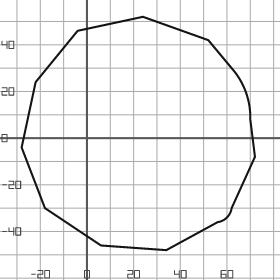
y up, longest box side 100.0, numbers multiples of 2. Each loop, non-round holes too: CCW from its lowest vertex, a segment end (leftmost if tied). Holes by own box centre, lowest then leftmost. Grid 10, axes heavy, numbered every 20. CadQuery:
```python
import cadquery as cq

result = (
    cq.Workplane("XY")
    .moveTo(34.0, -48.0)
    .lineTo(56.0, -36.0)
    .threePointArc((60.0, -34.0), (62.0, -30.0))
    .lineTo(72.0, -8.0)
    .lineTo(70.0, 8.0)
    .threePointArc((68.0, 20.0), (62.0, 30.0))
    .lineTo(52.0, 42.0)
    .lineTo(24.0, 52.0)
    .lineTo(-4.0, 46.0)
    .lineTo(-22.0, 24.0)
    .lineTo(-28.0, -4.0)
    .lineTo(-18.0, -30.0)
    .lineTo(6.0, -46.0)
    .close()
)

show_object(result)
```